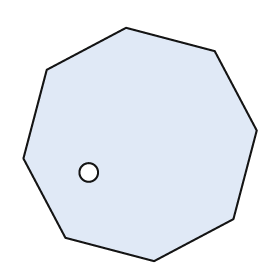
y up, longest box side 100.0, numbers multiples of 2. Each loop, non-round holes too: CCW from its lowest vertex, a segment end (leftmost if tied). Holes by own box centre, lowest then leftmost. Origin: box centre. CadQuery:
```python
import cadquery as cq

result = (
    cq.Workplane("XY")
    .moveTo(6.0, -50.0)
    .lineTo(40.0, -32.0)
    .lineTo(50.0, 6.0)
    .lineTo(32.0, 40.0)
    .lineTo(-6.0, 50.0)
    .lineTo(-40.0, 32.0)
    .lineTo(-50.0, -6.0)
    .lineTo(-32.0, -40.0)
    .close()
    .moveTo(-22.0, -12.0)
    .circle(4.0)
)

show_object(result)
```